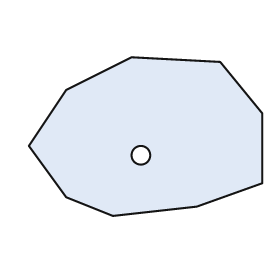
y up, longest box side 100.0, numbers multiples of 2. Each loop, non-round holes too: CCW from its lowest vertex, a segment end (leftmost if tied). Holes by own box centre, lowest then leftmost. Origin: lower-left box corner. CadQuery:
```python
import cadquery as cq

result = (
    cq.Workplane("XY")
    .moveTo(36.0, 0.0)
    .lineTo(72.0, 4.0)
    .lineTo(100.0, 14.0)
    .lineTo(100.0, 44.0)
    .lineTo(82.0, 66.0)
    .lineTo(44.0, 68.0)
    .lineTo(16.0, 54.0)
    .lineTo(0.0, 30.0)
    .lineTo(16.0, 8.0)
    .close()
    .moveTo(48.0, 26.0)
    .circle(4.0)
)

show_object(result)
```